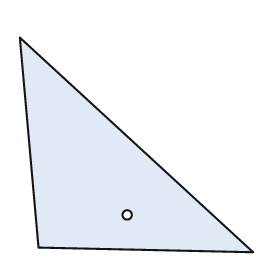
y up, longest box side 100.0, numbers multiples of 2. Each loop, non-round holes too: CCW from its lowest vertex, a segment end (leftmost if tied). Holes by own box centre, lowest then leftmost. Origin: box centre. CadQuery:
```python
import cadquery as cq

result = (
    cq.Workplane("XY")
    .moveTo(50.0, -46.0)
    .lineTo(-50.0, 46.0)
    .lineTo(-42.0, -44.0)
    .close()
    .moveTo(-4.0, -30.0)
    .circle(2.0)
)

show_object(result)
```